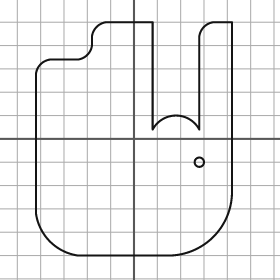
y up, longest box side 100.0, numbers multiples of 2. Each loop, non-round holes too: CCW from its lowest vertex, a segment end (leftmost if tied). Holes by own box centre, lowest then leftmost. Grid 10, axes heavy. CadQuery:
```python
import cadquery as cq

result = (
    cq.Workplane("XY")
    .moveTo(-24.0, -50.0)
    .lineTo(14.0, -50.0)
    .threePointArc((34.0, -42.0), (42.0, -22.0))
    .lineTo(42.0, 50.0)
    .lineTo(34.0, 50.0)
    .threePointArc((30.0, 48.0), (28.0, 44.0))
    .lineTo(28.0, 4.0)
    .threePointArc((18.0, 10.0), (8.0, 4.0))
    .lineTo(8.0, 50.0)
    .lineTo(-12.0, 50.0)
    .threePointArc((-16.0, 48.0), (-18.0, 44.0))
    .lineTo(-18.0, 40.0)
    .threePointArc((-20.0, 36.0), (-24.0, 34.0))
    .lineTo(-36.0, 34.0)
    .threePointArc((-40.0, 32.0), (-42.0, 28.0))
    .lineTo(-42.0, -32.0)
    .threePointArc((-36.0, -44.0), (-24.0, -50.0))
    .close()
    .moveTo(28.0, -10.0)
    .circle(2.0)
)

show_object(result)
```